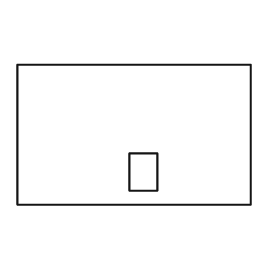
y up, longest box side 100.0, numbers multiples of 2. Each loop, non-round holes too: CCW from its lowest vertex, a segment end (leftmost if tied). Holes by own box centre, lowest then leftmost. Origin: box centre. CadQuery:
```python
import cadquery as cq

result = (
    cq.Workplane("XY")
    .moveTo(-50.0, -30.0)
    .lineTo(50.0, -30.0)
    .lineTo(50.0, 30.0)
    .lineTo(-50.0, 30.0)
    .close()
    .moveTo(-2.0, -24.0)
    .lineTo(10.0, -24.0)
    .lineTo(10.0, -8.0)
    .lineTo(-2.0, -8.0)
    .close()
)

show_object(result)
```